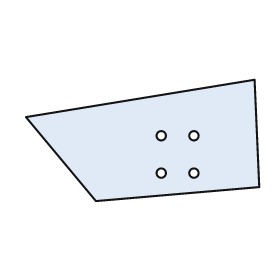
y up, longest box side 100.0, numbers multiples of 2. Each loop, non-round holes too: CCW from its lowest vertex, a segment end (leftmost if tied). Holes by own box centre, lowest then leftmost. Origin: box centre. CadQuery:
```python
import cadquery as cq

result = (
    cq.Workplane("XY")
    .moveTo(-20.0, -26.0)
    .lineTo(50.0, -20.0)
    .lineTo(48.0, 26.0)
    .lineTo(-50.0, 10.0)
    .close()
    .moveTo(8.0, -14.0)
    .circle(2.0)
    .moveTo(22.0, -14.0)
    .circle(2.0)
    .moveTo(8.0, 2.0)
    .circle(2.0)
    .moveTo(22.0, 2.0)
    .circle(2.0)
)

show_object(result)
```